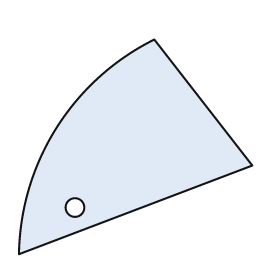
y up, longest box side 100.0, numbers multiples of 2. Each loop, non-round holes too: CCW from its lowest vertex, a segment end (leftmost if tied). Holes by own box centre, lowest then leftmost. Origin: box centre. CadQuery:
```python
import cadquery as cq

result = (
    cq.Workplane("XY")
    .moveTo(-50.0, -46.0)
    .lineTo(50.0, -8.0)
    .lineTo(8.0, 46.0)
    .threePointArc((-34.0, 8.0), (-50.0, -46.0))
    .close()
    .moveTo(-26.0, -26.0)
    .circle(4.0)
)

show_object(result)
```